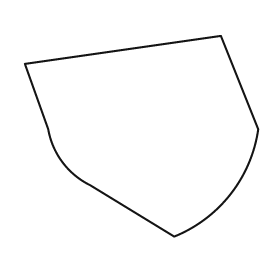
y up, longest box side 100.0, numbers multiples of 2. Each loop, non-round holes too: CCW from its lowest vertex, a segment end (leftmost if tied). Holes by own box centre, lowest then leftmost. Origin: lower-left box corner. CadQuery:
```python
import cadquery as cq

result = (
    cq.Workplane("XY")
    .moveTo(64.0, 0.0)
    .threePointArc((88.0, 18.0), (100.0, 46.0))
    .lineTo(84.0, 86.0)
    .lineTo(0.0, 74.0)
    .lineTo(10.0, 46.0)
    .threePointArc((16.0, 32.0), (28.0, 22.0))
    .close()
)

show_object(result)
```